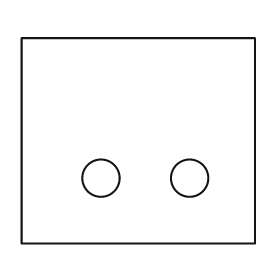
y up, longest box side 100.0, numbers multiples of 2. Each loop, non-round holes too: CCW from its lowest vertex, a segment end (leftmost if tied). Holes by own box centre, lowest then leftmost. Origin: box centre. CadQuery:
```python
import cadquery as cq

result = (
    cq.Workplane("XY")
    .moveTo(-50.0, -44.0)
    .lineTo(50.0, -44.0)
    .lineTo(50.0, 44.0)
    .lineTo(-50.0, 44.0)
    .close()
    .moveTo(-16.0, -16.0)
    .circle(8.0)
    .moveTo(22.0, -16.0)
    .circle(8.0)
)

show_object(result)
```